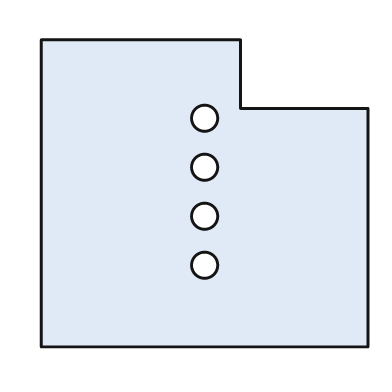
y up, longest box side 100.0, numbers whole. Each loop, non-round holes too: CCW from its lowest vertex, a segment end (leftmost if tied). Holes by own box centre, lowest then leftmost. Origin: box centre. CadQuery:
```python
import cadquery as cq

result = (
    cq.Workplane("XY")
    .moveTo(-50.0, -47.0)
    .lineTo(50.0, -47.0)
    .lineTo(50.0, 26.0)
    .lineTo(11.0, 26.0)
    .lineTo(11.0, 47.0)
    .lineTo(-50.0, 47.0)
    .close()
    .moveTo(0.0, -22.0)
    .circle(4.0)
    .moveTo(0.0, -7.0)
    .circle(4.0)
    .moveTo(0.0, 8.0)
    .circle(4.0)
    .moveTo(0.0, 23.0)
    .circle(4.0)
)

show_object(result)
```